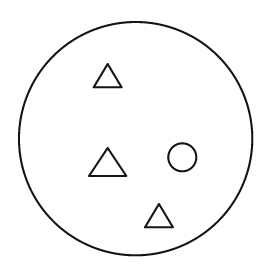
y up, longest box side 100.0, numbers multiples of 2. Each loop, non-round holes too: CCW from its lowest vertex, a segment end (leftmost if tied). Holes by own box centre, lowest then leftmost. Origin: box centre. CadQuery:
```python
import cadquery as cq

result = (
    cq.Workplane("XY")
    .moveTo(0.0, 0.0)
    .circle(50.0)
    .moveTo(4.0, -38.0)
    .lineTo(16.0, -38.0)
    .lineTo(10.0, -28.0)
    .close()
    .moveTo(-20.0, -16.0)
    .lineTo(-4.0, -16.0)
    .lineTo(-12.0, -4.0)
    .close()
    .moveTo(20.0, -8.0)
    .circle(6.0)
    .moveTo(-18.0, 22.0)
    .lineTo(-6.0, 22.0)
    .lineTo(-12.0, 32.0)
    .close()
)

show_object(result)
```